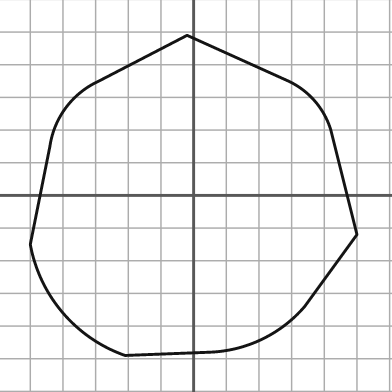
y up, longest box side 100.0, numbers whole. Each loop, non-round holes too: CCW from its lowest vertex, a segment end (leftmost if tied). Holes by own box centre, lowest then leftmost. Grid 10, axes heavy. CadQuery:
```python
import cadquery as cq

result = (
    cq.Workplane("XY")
    .moveTo(-21.0, -49.0)
    .lineTo(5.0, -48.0)
    .threePointArc((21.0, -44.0), (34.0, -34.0))
    .lineTo(50.0, -12.0)
    .lineTo(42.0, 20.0)
    .threePointArc((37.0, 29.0), (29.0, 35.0))
    .lineTo(-2.0, 49.0)
    .lineTo(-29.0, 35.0)
    .threePointArc((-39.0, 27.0), (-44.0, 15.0))
    .lineTo(-50.0, -15.0)
    .threePointArc((-40.0, -36.0), (-21.0, -49.0))
    .close()
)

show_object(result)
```